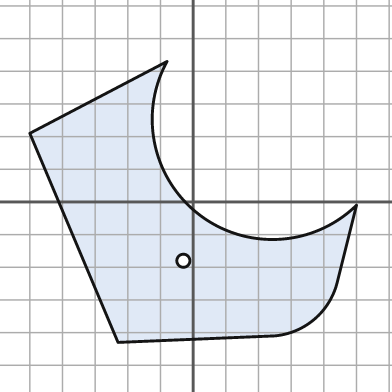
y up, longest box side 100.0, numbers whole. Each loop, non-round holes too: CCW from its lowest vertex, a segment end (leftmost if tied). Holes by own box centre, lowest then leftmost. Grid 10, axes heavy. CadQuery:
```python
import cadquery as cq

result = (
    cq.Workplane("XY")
    .moveTo(-23.0, -43.0)
    .lineTo(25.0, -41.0)
    .threePointArc((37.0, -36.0), (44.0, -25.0))
    .lineTo(50.0, -1.0)
    .threePointArc((2.0, -4.0), (-8.0, 43.0))
    .lineTo(-50.0, 21.0)
    .close()
    .moveTo(-3.0, -18.0)
    .circle(2.0)
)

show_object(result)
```